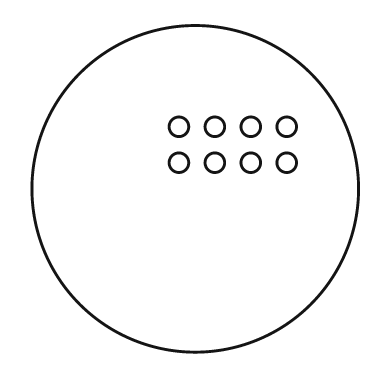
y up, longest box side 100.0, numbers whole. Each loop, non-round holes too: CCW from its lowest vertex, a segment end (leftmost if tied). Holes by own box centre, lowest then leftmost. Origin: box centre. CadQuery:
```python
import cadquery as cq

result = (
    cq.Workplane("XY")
    .moveTo(0.0, 0.0)
    .circle(50.0)
    .moveTo(-5.0, 8.0)
    .circle(3.0)
    .moveTo(6.0, 8.0)
    .circle(3.0)
    .moveTo(17.0, 8.0)
    .circle(3.0)
    .moveTo(28.0, 8.0)
    .circle(3.0)
    .moveTo(-5.0, 19.0)
    .circle(3.0)
    .moveTo(6.0, 19.0)
    .circle(3.0)
    .moveTo(17.0, 19.0)
    .circle(3.0)
    .moveTo(28.0, 19.0)
    .circle(3.0)
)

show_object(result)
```